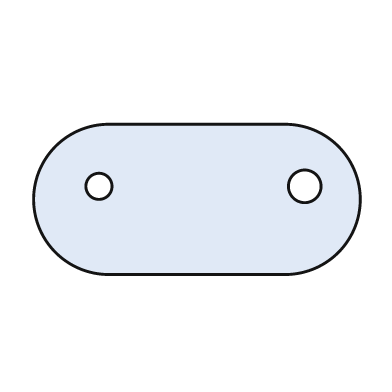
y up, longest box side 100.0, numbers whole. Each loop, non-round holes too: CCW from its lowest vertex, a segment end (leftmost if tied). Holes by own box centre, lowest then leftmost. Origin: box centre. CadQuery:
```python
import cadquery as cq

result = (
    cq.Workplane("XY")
    .moveTo(-27.0, -23.0)
    .lineTo(27.0, -23.0)
    .threePointArc((50.0, 0.0), (27.0, 23.0))
    .lineTo(-27.0, 23.0)
    .threePointArc((-50.0, 0.0), (-27.0, -23.0))
    .close()
    .moveTo(-30.0, 4.0)
    .circle(4.0)
    .moveTo(33.0, 4.0)
    .circle(5.0)
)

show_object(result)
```